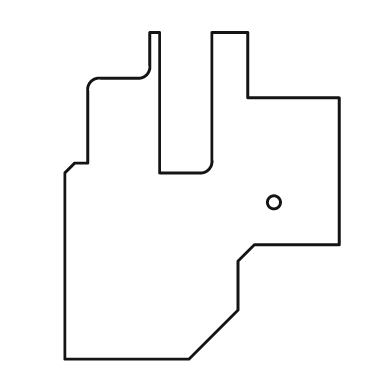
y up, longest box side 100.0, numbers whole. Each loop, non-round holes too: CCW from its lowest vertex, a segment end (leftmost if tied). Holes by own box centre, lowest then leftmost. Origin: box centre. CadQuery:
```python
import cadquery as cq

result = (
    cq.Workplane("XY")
    .moveTo(-42.0, -50.0)
    .lineTo(-4.0, -50.0)
    .lineTo(11.0, -35.0)
    .lineTo(11.0, -20.0)
    .lineTo(16.0, -15.0)
    .lineTo(42.0, -15.0)
    .lineTo(42.0, 30.0)
    .lineTo(14.0, 30.0)
    .lineTo(14.0, 50.0)
    .lineTo(3.0, 50.0)
    .lineTo(3.0, 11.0)
    .threePointArc((2.0, 8.0), (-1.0, 7.0))
    .lineTo(-13.0, 7.0)
    .lineTo(-13.0, 50.0)
    .lineTo(-16.0, 50.0)
    .lineTo(-16.0, 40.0)
    .threePointArc((-17.0, 37.0), (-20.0, 36.0))
    .lineTo(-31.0, 36.0)
    .threePointArc((-34.0, 35.0), (-35.0, 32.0))
    .lineTo(-35.0, 10.0)
    .lineTo(-39.0, 10.0)
    .lineTo(-42.0, 7.0)
    .close()
    .moveTo(22.0, -2.0)
    .circle(2.0)
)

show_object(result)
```